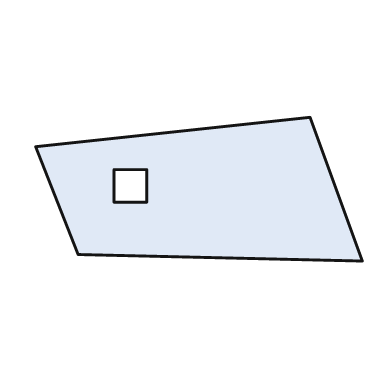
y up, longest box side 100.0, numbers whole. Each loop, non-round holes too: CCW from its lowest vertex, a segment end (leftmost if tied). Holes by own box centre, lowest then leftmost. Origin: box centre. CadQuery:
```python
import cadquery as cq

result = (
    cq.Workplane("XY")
    .moveTo(50.0, -22.0)
    .lineTo(34.0, 22.0)
    .lineTo(-50.0, 13.0)
    .lineTo(-37.0, -20.0)
    .close()
    .moveTo(-26.0, -4.0)
    .lineTo(-16.0, -4.0)
    .lineTo(-16.0, 6.0)
    .lineTo(-26.0, 6.0)
    .close()
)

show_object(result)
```